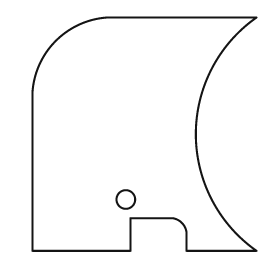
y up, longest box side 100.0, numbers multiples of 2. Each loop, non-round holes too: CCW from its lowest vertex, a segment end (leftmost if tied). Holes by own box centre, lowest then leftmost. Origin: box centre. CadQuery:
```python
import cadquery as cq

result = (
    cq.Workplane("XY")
    .moveTo(-48.0, -50.0)
    .lineTo(-6.0, -50.0)
    .lineTo(-6.0, -36.0)
    .lineTo(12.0, -36.0)
    .threePointArc((16.0, -38.0), (18.0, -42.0))
    .lineTo(18.0, -50.0)
    .lineTo(48.0, -50.0)
    .threePointArc((22.0, 0.0), (48.0, 50.0))
    .lineTo(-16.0, 50.0)
    .threePointArc((-38.0, 40.0), (-48.0, 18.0))
    .close()
    .moveTo(-8.0, -28.0)
    .circle(4.0)
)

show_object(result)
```